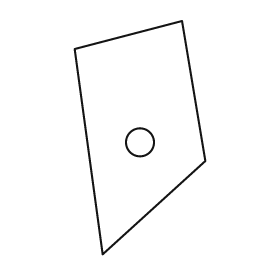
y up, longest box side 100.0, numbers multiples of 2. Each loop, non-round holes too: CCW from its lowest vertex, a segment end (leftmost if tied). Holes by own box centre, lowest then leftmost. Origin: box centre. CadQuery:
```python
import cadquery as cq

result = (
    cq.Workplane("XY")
    .moveTo(-16.0, -50.0)
    .lineTo(28.0, -10.0)
    .lineTo(18.0, 50.0)
    .lineTo(-28.0, 38.0)
    .close()
    .moveTo(0.0, -2.0)
    .circle(6.0)
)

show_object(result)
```